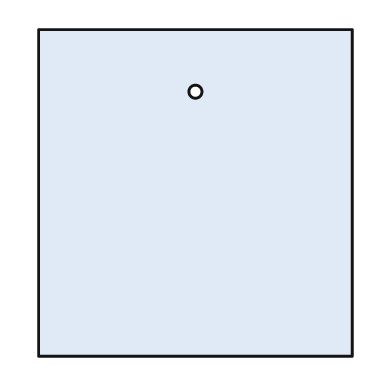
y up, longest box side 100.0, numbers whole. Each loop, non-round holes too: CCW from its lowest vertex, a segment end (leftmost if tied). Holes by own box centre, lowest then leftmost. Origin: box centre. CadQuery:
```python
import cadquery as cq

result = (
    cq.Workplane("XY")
    .moveTo(-48.0, -50.0)
    .lineTo(48.0, -50.0)
    .lineTo(48.0, 50.0)
    .lineTo(-48.0, 50.0)
    .close()
    .moveTo(0.0, 31.0)
    .circle(2.0)
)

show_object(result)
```